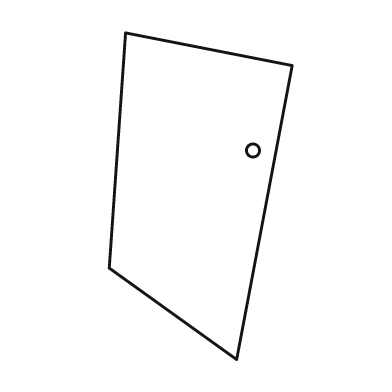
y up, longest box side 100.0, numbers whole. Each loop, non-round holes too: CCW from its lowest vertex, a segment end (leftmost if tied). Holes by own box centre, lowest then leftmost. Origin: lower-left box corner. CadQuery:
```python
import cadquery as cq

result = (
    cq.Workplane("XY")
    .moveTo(39.0, 0.0)
    .lineTo(56.0, 90.0)
    .lineTo(5.0, 100.0)
    .lineTo(0.0, 28.0)
    .close()
    .moveTo(44.0, 64.0)
    .circle(2.0)
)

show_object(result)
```